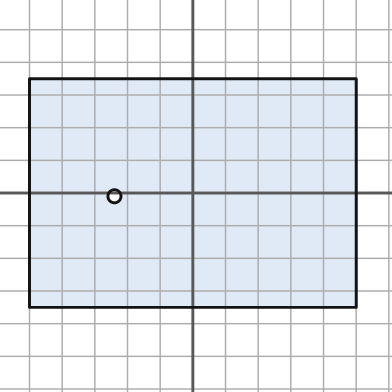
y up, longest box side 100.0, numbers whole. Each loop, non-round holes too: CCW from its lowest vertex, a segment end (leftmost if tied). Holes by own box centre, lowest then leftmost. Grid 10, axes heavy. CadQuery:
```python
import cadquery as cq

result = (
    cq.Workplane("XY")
    .moveTo(-50.0, -35.0)
    .lineTo(50.0, -35.0)
    .lineTo(50.0, 35.0)
    .lineTo(-50.0, 35.0)
    .close()
    .moveTo(-24.0, -1.0)
    .circle(2.0)
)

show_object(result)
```